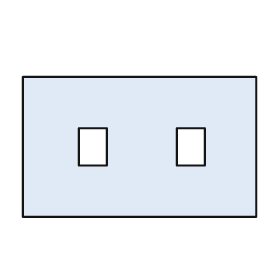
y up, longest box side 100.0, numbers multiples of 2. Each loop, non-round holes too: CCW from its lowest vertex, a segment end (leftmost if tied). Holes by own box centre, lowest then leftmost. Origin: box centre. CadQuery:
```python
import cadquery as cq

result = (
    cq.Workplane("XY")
    .moveTo(-50.0, -30.0)
    .lineTo(50.0, -30.0)
    .lineTo(50.0, 30.0)
    .lineTo(-50.0, 30.0)
    .close()
    .moveTo(-26.0, -8.0)
    .lineTo(-14.0, -8.0)
    .lineTo(-14.0, 8.0)
    .lineTo(-26.0, 8.0)
    .close()
    .moveTo(16.0, -8.0)
    .lineTo(28.0, -8.0)
    .lineTo(28.0, 8.0)
    .lineTo(16.0, 8.0)
    .close()
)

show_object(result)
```